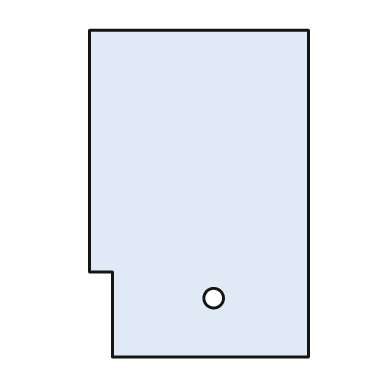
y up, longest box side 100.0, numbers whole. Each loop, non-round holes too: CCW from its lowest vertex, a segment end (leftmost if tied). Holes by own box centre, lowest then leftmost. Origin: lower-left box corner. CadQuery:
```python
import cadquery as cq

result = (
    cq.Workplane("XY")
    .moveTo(7.0, 0.0)
    .lineTo(67.0, 0.0)
    .lineTo(67.0, 100.0)
    .lineTo(0.0, 100.0)
    .lineTo(0.0, 26.0)
    .lineTo(7.0, 26.0)
    .close()
    .moveTo(38.0, 18.0)
    .circle(3.0)
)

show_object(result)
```